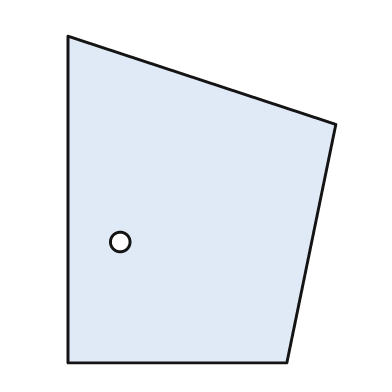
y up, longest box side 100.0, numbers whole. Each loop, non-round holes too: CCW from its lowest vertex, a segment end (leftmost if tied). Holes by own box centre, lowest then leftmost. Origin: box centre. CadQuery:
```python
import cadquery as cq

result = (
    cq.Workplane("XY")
    .moveTo(-41.0, -50.0)
    .lineTo(26.0, -50.0)
    .lineTo(41.0, 23.0)
    .lineTo(-41.0, 50.0)
    .close()
    .moveTo(-25.0, -13.0)
    .circle(3.0)
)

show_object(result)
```